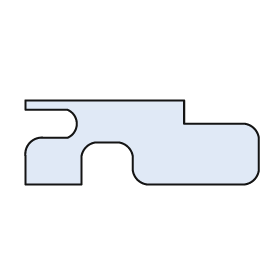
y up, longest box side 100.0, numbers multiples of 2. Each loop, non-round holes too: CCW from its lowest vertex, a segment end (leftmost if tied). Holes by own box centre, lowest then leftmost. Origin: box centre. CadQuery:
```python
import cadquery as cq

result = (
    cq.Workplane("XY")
    .moveTo(-50.0, -18.0)
    .lineTo(-26.0, -18.0)
    .lineTo(-26.0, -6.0)
    .threePointArc((-24.0, -2.0), (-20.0, 0.0))
    .lineTo(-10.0, 0.0)
    .threePointArc((-6.0, -2.0), (-4.0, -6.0))
    .lineTo(-4.0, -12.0)
    .threePointArc((-2.0, -16.0), (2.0, -18.0))
    .lineTo(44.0, -18.0)
    .threePointArc((48.0, -16.0), (50.0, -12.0))
    .lineTo(50.0, 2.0)
    .threePointArc((48.0, 6.0), (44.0, 8.0))
    .lineTo(18.0, 8.0)
    .lineTo(18.0, 18.0)
    .lineTo(-50.0, 18.0)
    .lineTo(-50.0, 14.0)
    .lineTo(-32.0, 14.0)
    .threePointArc((-28.0, 8.0), (-32.0, 2.0))
    .lineTo(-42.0, 2.0)
    .threePointArc((-48.0, 0.0), (-50.0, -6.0))
    .close()
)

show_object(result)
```